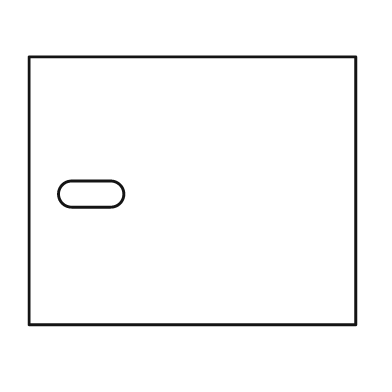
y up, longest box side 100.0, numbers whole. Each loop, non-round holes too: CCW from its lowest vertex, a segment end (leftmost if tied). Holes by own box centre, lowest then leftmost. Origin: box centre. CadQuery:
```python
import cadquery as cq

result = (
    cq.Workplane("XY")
    .moveTo(-50.0, -41.0)
    .lineTo(50.0, -41.0)
    .lineTo(50.0, 41.0)
    .lineTo(-50.0, 41.0)
    .close()
    .moveTo(-37.0, -5.0)
    .lineTo(-25.0, -5.0)
    .threePointArc((-21.0, -1.0), (-25.0, 3.0))
    .lineTo(-37.0, 3.0)
    .threePointArc((-41.0, -1.0), (-37.0, -5.0))
    .close()
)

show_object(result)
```